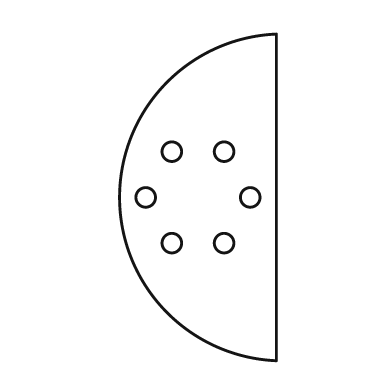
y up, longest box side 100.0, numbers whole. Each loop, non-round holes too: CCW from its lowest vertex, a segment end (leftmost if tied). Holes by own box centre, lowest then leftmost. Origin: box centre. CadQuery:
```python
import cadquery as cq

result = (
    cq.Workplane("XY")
    .moveTo(24.0, -50.0)
    .lineTo(24.0, 50.0)
    .threePointArc((-24.0, 0.0), (24.0, -50.0))
    .close()
    .moveTo(-8.0, -14.0)
    .circle(3.0)
    .moveTo(8.0, -14.0)
    .circle(3.0)
    .moveTo(-16.0, 0.0)
    .circle(3.0)
    .moveTo(16.0, 0.0)
    .circle(3.0)
    .moveTo(-8.0, 14.0)
    .circle(3.0)
    .moveTo(8.0, 14.0)
    .circle(3.0)
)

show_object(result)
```